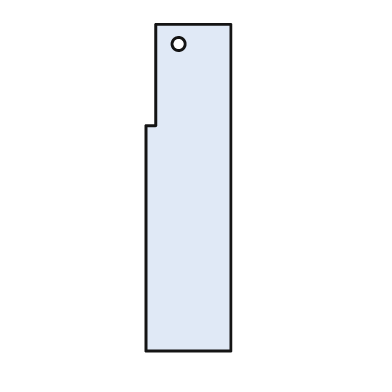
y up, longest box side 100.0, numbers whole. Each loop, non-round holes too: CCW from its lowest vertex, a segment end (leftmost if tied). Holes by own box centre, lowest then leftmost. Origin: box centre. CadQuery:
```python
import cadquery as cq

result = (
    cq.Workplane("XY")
    .moveTo(-13.0, -50.0)
    .lineTo(13.0, -50.0)
    .lineTo(13.0, 50.0)
    .lineTo(-10.0, 50.0)
    .lineTo(-10.0, 19.0)
    .lineTo(-13.0, 19.0)
    .close()
    .moveTo(-3.0, 44.0)
    .circle(2.0)
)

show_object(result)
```